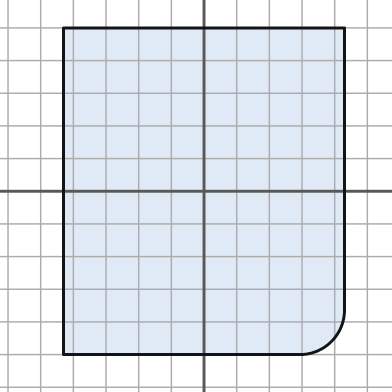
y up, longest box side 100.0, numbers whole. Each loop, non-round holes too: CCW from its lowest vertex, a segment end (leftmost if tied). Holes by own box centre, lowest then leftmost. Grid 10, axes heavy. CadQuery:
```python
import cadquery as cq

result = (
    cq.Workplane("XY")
    .moveTo(-43.0, -50.0)
    .lineTo(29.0, -50.0)
    .threePointArc((39.0, -46.0), (43.0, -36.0))
    .lineTo(43.0, 50.0)
    .lineTo(-43.0, 50.0)
    .close()
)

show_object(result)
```